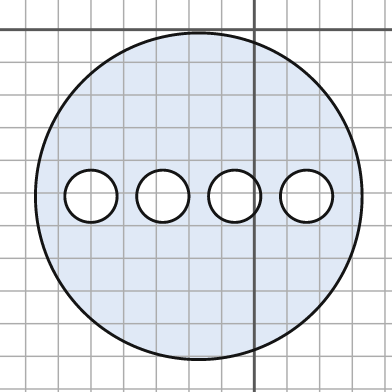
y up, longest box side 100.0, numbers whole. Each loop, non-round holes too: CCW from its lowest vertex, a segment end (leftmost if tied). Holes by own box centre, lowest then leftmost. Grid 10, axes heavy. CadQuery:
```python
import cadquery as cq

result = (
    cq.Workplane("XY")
    .moveTo(-17.0, -51.0)
    .circle(50.0)
    .moveTo(-50.0, -51.0)
    .circle(8.0)
    .moveTo(-28.0, -51.0)
    .circle(8.0)
    .moveTo(-6.0, -51.0)
    .circle(8.0)
    .moveTo(16.0, -51.0)
    .circle(8.0)
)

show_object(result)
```